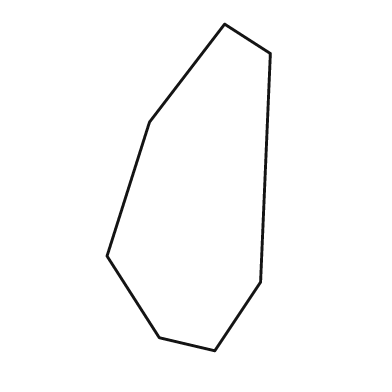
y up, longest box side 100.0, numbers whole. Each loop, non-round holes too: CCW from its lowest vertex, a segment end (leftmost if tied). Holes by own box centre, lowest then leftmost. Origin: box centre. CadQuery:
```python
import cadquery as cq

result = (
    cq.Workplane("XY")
    .moveTo(8.0, -50.0)
    .lineTo(22.0, -29.0)
    .lineTo(25.0, 41.0)
    .lineTo(11.0, 50.0)
    .lineTo(-12.0, 20.0)
    .lineTo(-25.0, -21.0)
    .lineTo(-9.0, -46.0)
    .close()
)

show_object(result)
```